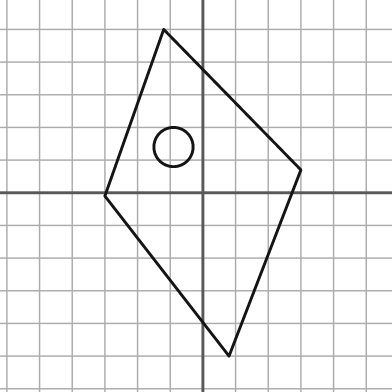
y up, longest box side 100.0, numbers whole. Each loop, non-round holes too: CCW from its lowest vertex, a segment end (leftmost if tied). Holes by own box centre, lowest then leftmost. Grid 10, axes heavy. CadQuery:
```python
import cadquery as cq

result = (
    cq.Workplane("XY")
    .moveTo(8.0, -50.0)
    .lineTo(30.0, 7.0)
    .lineTo(-12.0, 50.0)
    .lineTo(-30.0, -1.0)
    .close()
    .moveTo(-9.0, 14.0)
    .circle(6.0)
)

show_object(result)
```